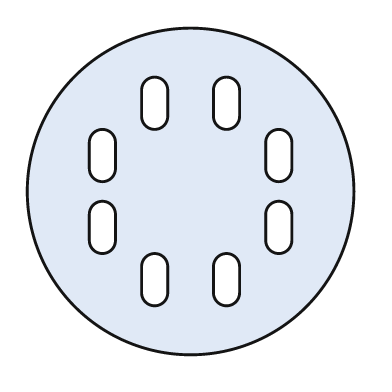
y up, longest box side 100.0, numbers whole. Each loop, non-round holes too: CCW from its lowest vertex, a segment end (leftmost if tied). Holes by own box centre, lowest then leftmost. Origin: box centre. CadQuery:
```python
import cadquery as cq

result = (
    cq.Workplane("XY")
    .moveTo(0.0, 0.0)
    .circle(50.0)
    .moveTo(-15.0, -31.0)
    .threePointArc((-11.0, -35.0), (-7.0, -31.0))
    .lineTo(-7.0, -23.0)
    .threePointArc((-11.0, -19.0), (-15.0, -23.0))
    .close()
    .moveTo(7.0, -31.0)
    .threePointArc((11.0, -35.0), (15.0, -31.0))
    .lineTo(15.0, -23.0)
    .threePointArc((11.0, -19.0), (7.0, -23.0))
    .close()
    .moveTo(-31.0, -15.0)
    .threePointArc((-27.0, -19.0), (-23.0, -15.0))
    .lineTo(-23.0, -7.0)
    .threePointArc((-27.0, -3.0), (-31.0, -7.0))
    .close()
    .moveTo(23.0, -15.0)
    .threePointArc((27.0, -19.0), (31.0, -15.0))
    .lineTo(31.0, -7.0)
    .threePointArc((27.0, -3.0), (23.0, -7.0))
    .close()
    .moveTo(-31.0, 7.0)
    .threePointArc((-27.0, 3.0), (-23.0, 7.0))
    .lineTo(-23.0, 15.0)
    .threePointArc((-27.0, 19.0), (-31.0, 15.0))
    .close()
    .moveTo(23.0, 7.0)
    .threePointArc((27.0, 3.0), (31.0, 7.0))
    .lineTo(31.0, 15.0)
    .threePointArc((27.0, 19.0), (23.0, 15.0))
    .close()
    .moveTo(-15.0, 23.0)
    .threePointArc((-11.0, 19.0), (-7.0, 23.0))
    .lineTo(-7.0, 31.0)
    .threePointArc((-11.0, 35.0), (-15.0, 31.0))
    .close()
    .moveTo(7.0, 23.0)
    .threePointArc((11.0, 19.0), (15.0, 23.0))
    .lineTo(15.0, 31.0)
    .threePointArc((11.0, 35.0), (7.0, 31.0))
    .close()
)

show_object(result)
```